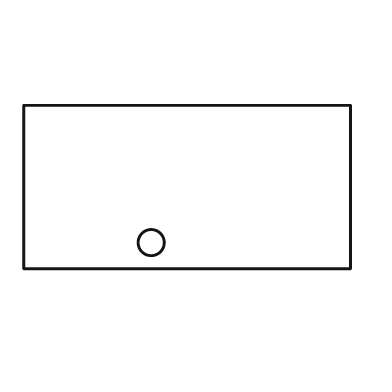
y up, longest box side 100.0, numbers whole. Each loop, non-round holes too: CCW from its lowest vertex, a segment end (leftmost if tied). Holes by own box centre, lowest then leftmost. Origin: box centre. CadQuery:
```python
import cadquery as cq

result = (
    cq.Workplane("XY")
    .moveTo(-50.0, -25.0)
    .lineTo(50.0, -25.0)
    .lineTo(50.0, 25.0)
    .lineTo(-50.0, 25.0)
    .close()
    .moveTo(-11.0, -17.0)
    .circle(4.0)
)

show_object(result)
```